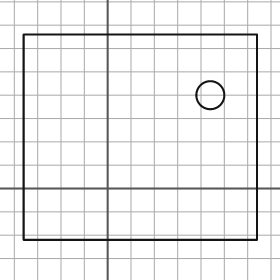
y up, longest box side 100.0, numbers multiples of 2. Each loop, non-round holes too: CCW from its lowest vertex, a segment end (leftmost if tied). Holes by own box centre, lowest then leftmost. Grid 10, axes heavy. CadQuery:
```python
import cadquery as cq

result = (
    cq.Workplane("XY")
    .moveTo(-36.0, -22.0)
    .lineTo(64.0, -22.0)
    .lineTo(64.0, 66.0)
    .lineTo(-36.0, 66.0)
    .close()
    .moveTo(44.0, 40.0)
    .circle(6.0)
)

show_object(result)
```